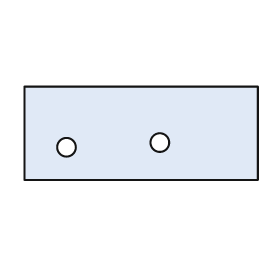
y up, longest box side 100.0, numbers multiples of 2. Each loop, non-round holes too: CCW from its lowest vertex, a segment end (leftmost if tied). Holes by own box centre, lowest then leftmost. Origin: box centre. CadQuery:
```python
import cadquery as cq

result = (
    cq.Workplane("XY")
    .moveTo(-50.0, -20.0)
    .lineTo(50.0, -20.0)
    .lineTo(50.0, 20.0)
    .lineTo(-50.0, 20.0)
    .close()
    .moveTo(-32.0, -6.0)
    .circle(4.0)
    .moveTo(8.0, -4.0)
    .circle(4.0)
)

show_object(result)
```